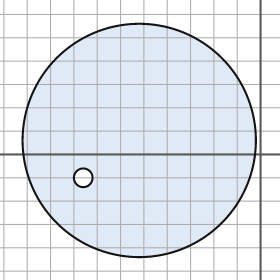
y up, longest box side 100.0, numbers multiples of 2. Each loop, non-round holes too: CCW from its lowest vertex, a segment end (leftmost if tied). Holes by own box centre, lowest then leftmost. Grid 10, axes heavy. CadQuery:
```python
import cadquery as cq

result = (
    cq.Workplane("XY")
    .moveTo(-52.0, 6.0)
    .circle(50.0)
    .moveTo(-76.0, -10.0)
    .circle(4.0)
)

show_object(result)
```